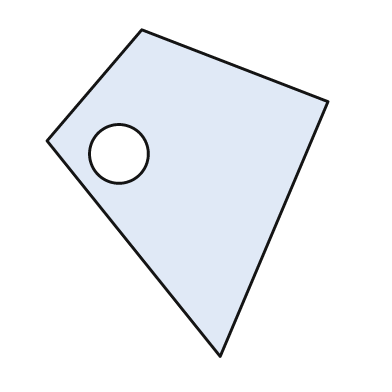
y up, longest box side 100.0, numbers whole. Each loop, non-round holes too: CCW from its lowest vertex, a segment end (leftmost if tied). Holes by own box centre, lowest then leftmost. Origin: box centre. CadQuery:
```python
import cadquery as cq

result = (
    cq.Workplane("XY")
    .moveTo(10.0, -50.0)
    .lineTo(43.0, 28.0)
    .lineTo(-14.0, 50.0)
    .lineTo(-43.0, 16.0)
    .close()
    .moveTo(-21.0, 12.0)
    .circle(9.0)
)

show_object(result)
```